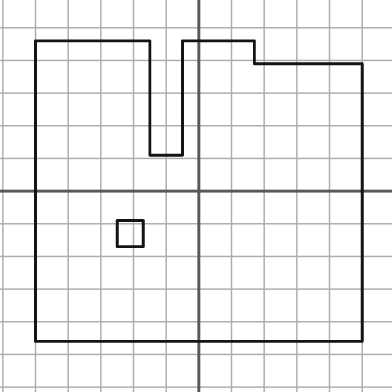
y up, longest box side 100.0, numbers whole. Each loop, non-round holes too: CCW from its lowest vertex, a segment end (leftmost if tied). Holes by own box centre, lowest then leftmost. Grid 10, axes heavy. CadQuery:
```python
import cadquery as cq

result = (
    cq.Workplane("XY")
    .moveTo(-50.0, -46.0)
    .lineTo(50.0, -46.0)
    .lineTo(50.0, 39.0)
    .lineTo(17.0, 39.0)
    .lineTo(17.0, 46.0)
    .lineTo(-5.0, 46.0)
    .lineTo(-5.0, 11.0)
    .lineTo(-15.0, 11.0)
    .lineTo(-15.0, 46.0)
    .lineTo(-50.0, 46.0)
    .close()
    .moveTo(-25.0, -17.0)
    .lineTo(-17.0, -17.0)
    .lineTo(-17.0, -9.0)
    .lineTo(-25.0, -9.0)
    .close()
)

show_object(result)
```